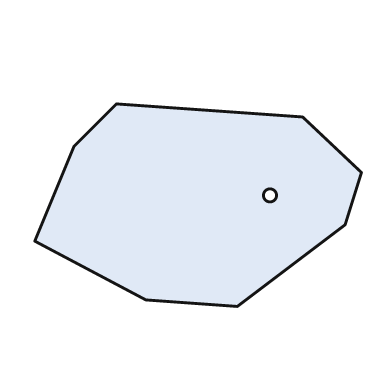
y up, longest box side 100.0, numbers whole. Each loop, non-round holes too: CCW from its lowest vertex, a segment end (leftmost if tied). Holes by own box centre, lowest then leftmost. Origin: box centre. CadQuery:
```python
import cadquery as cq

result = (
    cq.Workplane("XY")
    .moveTo(12.0, -31.0)
    .lineTo(45.0, -6.0)
    .lineTo(50.0, 10.0)
    .lineTo(32.0, 27.0)
    .lineTo(-25.0, 31.0)
    .lineTo(-38.0, 18.0)
    .lineTo(-50.0, -11.0)
    .lineTo(-16.0, -29.0)
    .close()
    .moveTo(22.0, 3.0)
    .circle(2.0)
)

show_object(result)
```